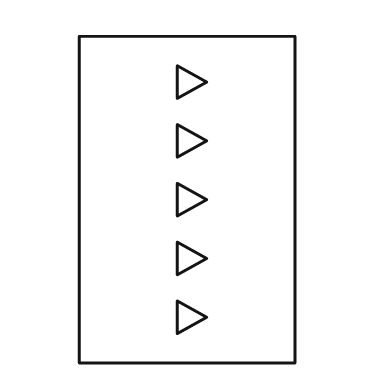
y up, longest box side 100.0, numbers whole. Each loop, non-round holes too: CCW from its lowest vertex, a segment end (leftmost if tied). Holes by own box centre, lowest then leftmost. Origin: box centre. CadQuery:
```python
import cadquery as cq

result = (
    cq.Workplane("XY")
    .moveTo(-33.0, -50.0)
    .lineTo(33.0, -50.0)
    .lineTo(33.0, 50.0)
    .lineTo(-33.0, 50.0)
    .close()
    .moveTo(-3.0, -41.0)
    .lineTo(6.0, -36.0)
    .lineTo(-3.0, -31.0)
    .close()
    .moveTo(-3.0, -23.0)
    .lineTo(6.0, -18.0)
    .lineTo(-3.0, -13.0)
    .close()
    .moveTo(-3.0, -5.0)
    .lineTo(6.0, 0.0)
    .lineTo(-3.0, 5.0)
    .close()
    .moveTo(-3.0, 13.0)
    .lineTo(6.0, 18.0)
    .lineTo(-3.0, 23.0)
    .close()
    .moveTo(-3.0, 31.0)
    .lineTo(6.0, 36.0)
    .lineTo(-3.0, 41.0)
    .close()
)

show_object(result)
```